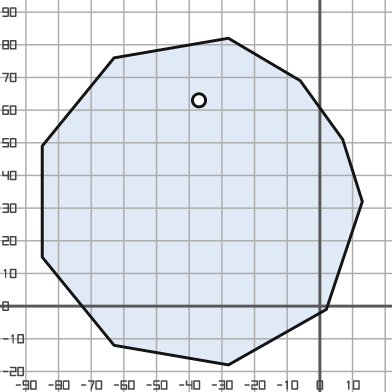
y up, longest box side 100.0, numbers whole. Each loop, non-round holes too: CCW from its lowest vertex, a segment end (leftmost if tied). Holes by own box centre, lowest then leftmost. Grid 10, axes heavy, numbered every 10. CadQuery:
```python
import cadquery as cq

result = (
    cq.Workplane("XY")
    .moveTo(-28.0, -18.0)
    .lineTo(2.0, -1.0)
    .lineTo(13.0, 32.0)
    .lineTo(7.0, 51.0)
    .lineTo(-6.0, 69.0)
    .lineTo(-28.0, 82.0)
    .lineTo(-63.0, 76.0)
    .lineTo(-85.0, 49.0)
    .lineTo(-85.0, 15.0)
    .lineTo(-63.0, -12.0)
    .close()
    .moveTo(-37.0, 63.0)
    .circle(2.0)
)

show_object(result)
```